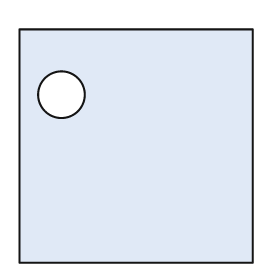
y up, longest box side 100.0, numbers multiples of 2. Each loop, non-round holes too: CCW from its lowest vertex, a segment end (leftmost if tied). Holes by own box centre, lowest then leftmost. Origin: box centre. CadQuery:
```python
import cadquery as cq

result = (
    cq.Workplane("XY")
    .moveTo(-50.0, -50.0)
    .lineTo(50.0, -50.0)
    .lineTo(50.0, 50.0)
    .lineTo(-50.0, 50.0)
    .close()
    .moveTo(-32.0, 22.0)
    .circle(10.0)
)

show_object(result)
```